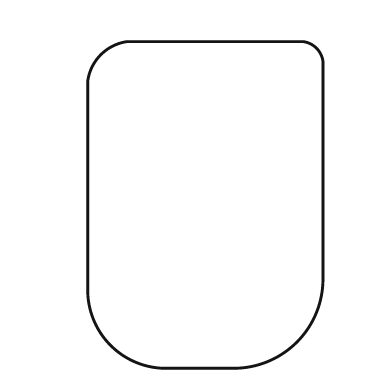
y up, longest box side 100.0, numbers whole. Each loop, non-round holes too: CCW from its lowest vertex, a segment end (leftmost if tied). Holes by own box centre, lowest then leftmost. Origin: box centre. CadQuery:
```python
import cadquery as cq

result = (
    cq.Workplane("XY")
    .moveTo(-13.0, -50.0)
    .lineTo(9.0, -50.0)
    .threePointArc((28.0, -42.0), (36.0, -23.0))
    .lineTo(36.0, 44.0)
    .threePointArc((34.0, 48.0), (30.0, 50.0))
    .lineTo(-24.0, 50.0)
    .threePointArc((-32.0, 46.0), (-36.0, 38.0))
    .lineTo(-36.0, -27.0)
    .threePointArc((-29.0, -43.0), (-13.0, -50.0))
    .close()
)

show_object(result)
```